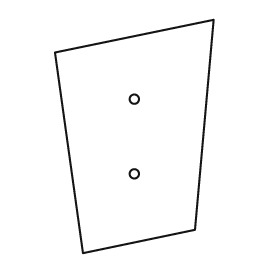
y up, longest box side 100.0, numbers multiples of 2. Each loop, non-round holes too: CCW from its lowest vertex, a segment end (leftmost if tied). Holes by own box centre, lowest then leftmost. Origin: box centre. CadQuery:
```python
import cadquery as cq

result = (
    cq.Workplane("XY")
    .moveTo(-22.0, -50.0)
    .lineTo(26.0, -40.0)
    .lineTo(34.0, 50.0)
    .lineTo(-34.0, 36.0)
    .close()
    .moveTo(0.0, -16.0)
    .circle(2.0)
    .moveTo(0.0, 16.0)
    .circle(2.0)
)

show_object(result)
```